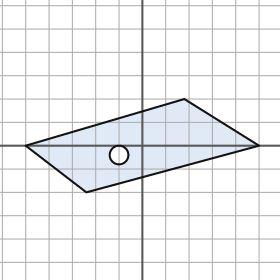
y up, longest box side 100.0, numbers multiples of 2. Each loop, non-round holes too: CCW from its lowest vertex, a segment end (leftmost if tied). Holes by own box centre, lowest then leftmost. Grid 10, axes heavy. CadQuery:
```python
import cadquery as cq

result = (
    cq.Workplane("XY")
    .moveTo(-24.0, -20.0)
    .lineTo(50.0, 0.0)
    .lineTo(18.0, 20.0)
    .lineTo(-50.0, 0.0)
    .close()
    .moveTo(-10.0, -4.0)
    .circle(4.0)
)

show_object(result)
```